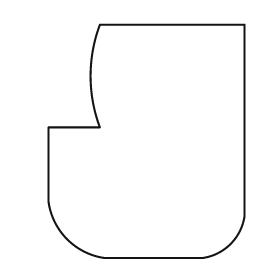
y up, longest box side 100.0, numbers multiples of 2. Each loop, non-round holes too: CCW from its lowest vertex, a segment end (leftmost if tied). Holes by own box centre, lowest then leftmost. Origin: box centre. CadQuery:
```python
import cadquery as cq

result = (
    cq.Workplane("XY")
    .moveTo(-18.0, -50.0)
    .lineTo(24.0, -50.0)
    .threePointArc((36.0, -44.0), (42.0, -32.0))
    .lineTo(42.0, 50.0)
    .lineTo(-20.0, 50.0)
    .threePointArc((-24.0, 28.0), (-20.0, 6.0))
    .lineTo(-42.0, 6.0)
    .lineTo(-42.0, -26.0)
    .threePointArc((-34.0, -42.0), (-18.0, -50.0))
    .close()
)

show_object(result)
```